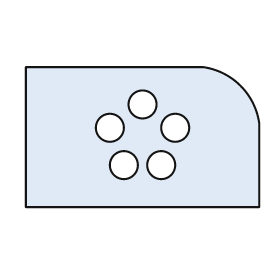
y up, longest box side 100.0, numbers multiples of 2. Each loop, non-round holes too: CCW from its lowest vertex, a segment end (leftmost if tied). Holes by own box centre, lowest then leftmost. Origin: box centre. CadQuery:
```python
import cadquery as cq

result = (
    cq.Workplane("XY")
    .moveTo(-50.0, -30.0)
    .lineTo(50.0, -30.0)
    .lineTo(50.0, 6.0)
    .threePointArc((42.0, 22.0), (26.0, 30.0))
    .lineTo(-50.0, 30.0)
    .close()
    .moveTo(-8.0, -12.0)
    .circle(6.0)
    .moveTo(8.0, -12.0)
    .circle(6.0)
    .moveTo(-14.0, 4.0)
    .circle(6.0)
    .moveTo(14.0, 4.0)
    .circle(6.0)
    .moveTo(0.0, 14.0)
    .circle(6.0)
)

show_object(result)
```